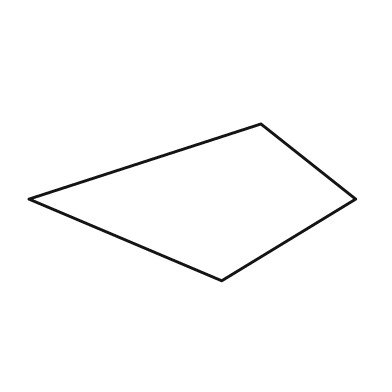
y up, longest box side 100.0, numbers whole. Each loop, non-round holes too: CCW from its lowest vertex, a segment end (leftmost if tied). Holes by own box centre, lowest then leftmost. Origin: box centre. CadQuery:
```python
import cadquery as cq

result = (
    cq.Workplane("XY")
    .moveTo(9.0, -24.0)
    .lineTo(50.0, 1.0)
    .lineTo(21.0, 24.0)
    .lineTo(-50.0, 1.0)
    .close()
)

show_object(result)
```